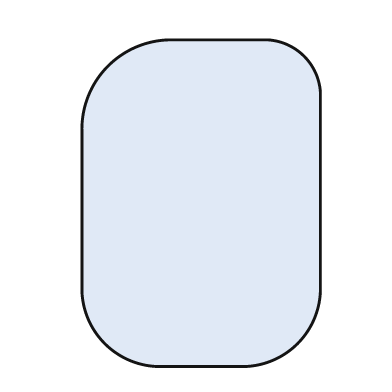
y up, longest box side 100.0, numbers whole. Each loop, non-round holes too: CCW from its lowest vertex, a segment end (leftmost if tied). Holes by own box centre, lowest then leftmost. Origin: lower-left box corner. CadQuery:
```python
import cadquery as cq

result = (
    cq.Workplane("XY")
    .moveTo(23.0, 0.0)
    .lineTo(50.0, 0.0)
    .threePointArc((66.0, 7.0), (73.0, 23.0))
    .lineTo(73.0, 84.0)
    .threePointArc((68.0, 95.0), (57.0, 100.0))
    .lineTo(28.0, 100.0)
    .threePointArc((8.0, 92.0), (0.0, 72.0))
    .lineTo(0.0, 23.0)
    .threePointArc((7.0, 7.0), (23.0, 0.0))
    .close()
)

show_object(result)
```